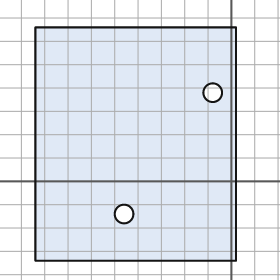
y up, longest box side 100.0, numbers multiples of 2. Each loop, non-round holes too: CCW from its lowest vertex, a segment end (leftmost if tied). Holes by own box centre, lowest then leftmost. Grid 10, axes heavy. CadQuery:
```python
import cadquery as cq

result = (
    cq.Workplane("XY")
    .moveTo(-84.0, -34.0)
    .lineTo(2.0, -34.0)
    .lineTo(2.0, 66.0)
    .lineTo(-84.0, 66.0)
    .close()
    .moveTo(-46.0, -14.0)
    .circle(4.0)
    .moveTo(-8.0, 38.0)
    .circle(4.0)
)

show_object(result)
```